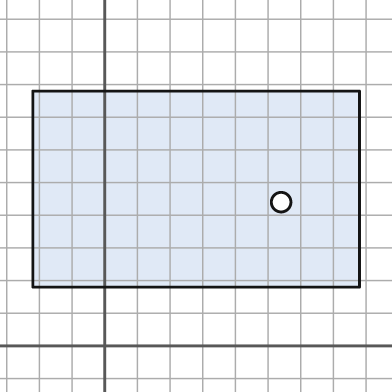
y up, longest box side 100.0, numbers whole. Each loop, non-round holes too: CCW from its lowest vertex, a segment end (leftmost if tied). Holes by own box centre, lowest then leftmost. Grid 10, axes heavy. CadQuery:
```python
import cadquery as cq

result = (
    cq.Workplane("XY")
    .moveTo(-22.0, 18.0)
    .lineTo(78.0, 18.0)
    .lineTo(78.0, 78.0)
    .lineTo(-22.0, 78.0)
    .close()
    .moveTo(54.0, 44.0)
    .circle(3.0)
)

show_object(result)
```